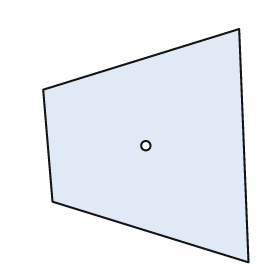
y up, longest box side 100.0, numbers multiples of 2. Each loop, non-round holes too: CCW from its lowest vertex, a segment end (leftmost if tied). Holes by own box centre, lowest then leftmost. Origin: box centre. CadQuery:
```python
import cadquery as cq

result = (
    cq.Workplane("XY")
    .moveTo(44.0, -50.0)
    .lineTo(40.0, 50.0)
    .lineTo(-44.0, 24.0)
    .lineTo(-40.0, -24.0)
    .close()
    .moveTo(0.0, 0.0)
    .circle(2.0)
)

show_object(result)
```